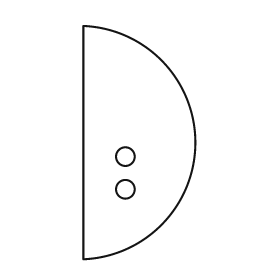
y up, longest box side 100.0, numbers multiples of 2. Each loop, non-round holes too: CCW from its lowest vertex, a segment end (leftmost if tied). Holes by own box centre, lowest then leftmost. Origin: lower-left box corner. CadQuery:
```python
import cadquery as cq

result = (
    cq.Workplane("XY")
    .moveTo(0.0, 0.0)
    .threePointArc((48.0, 50.0), (0.0, 100.0))
    .close()
    .moveTo(18.0, 30.0)
    .circle(4.0)
    .moveTo(18.0, 44.0)
    .circle(4.0)
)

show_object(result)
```